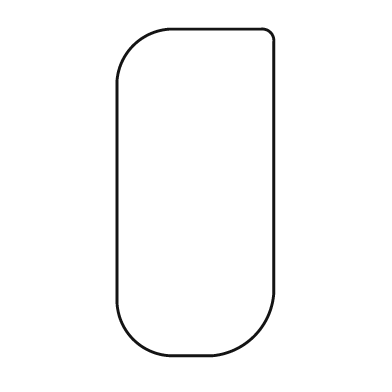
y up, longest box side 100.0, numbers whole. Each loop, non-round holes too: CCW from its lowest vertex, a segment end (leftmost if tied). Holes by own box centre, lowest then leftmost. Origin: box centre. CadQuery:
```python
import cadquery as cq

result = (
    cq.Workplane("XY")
    .moveTo(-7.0, -50.0)
    .lineTo(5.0, -50.0)
    .threePointArc((18.0, -44.0), (24.0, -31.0))
    .lineTo(24.0, 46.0)
    .threePointArc((23.0, 49.0), (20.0, 50.0))
    .lineTo(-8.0, 50.0)
    .threePointArc((-19.0, 45.0), (-24.0, 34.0))
    .lineTo(-24.0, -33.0)
    .threePointArc((-19.0, -45.0), (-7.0, -50.0))
    .close()
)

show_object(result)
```